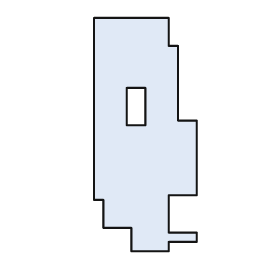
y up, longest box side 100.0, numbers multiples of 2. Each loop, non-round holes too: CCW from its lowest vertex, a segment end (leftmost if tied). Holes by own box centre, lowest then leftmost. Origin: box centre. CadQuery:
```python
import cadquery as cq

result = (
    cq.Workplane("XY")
    .moveTo(-6.0, -50.0)
    .lineTo(10.0, -50.0)
    .lineTo(10.0, -46.0)
    .lineTo(22.0, -46.0)
    .lineTo(22.0, -42.0)
    .lineTo(10.0, -42.0)
    .lineTo(10.0, -26.0)
    .lineTo(22.0, -26.0)
    .lineTo(22.0, 6.0)
    .lineTo(14.0, 6.0)
    .lineTo(14.0, 38.0)
    .lineTo(10.0, 38.0)
    .lineTo(10.0, 50.0)
    .lineTo(-22.0, 50.0)
    .lineTo(-22.0, -28.0)
    .lineTo(-18.0, -28.0)
    .lineTo(-18.0, -40.0)
    .lineTo(-6.0, -40.0)
    .close()
    .moveTo(-8.0, 4.0)
    .lineTo(0.0, 4.0)
    .lineTo(0.0, 20.0)
    .lineTo(-8.0, 20.0)
    .close()
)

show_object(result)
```